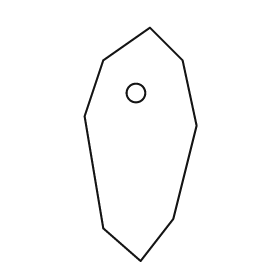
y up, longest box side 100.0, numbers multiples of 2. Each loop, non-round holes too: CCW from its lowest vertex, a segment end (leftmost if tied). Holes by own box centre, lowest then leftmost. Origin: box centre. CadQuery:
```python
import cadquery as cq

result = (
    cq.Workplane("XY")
    .moveTo(0.0, -50.0)
    .lineTo(14.0, -32.0)
    .lineTo(24.0, 8.0)
    .lineTo(18.0, 36.0)
    .lineTo(4.0, 50.0)
    .lineTo(-16.0, 36.0)
    .lineTo(-24.0, 12.0)
    .lineTo(-16.0, -36.0)
    .close()
    .moveTo(-2.0, 22.0)
    .circle(4.0)
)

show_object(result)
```